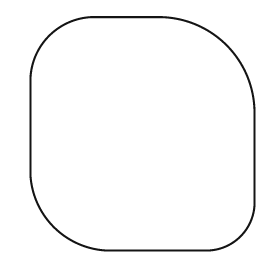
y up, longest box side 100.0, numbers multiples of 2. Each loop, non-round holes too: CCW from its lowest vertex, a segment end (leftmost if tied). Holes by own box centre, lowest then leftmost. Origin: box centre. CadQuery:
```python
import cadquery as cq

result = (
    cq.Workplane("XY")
    .moveTo(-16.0, -50.0)
    .lineTo(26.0, -50.0)
    .threePointArc((42.0, -44.0), (48.0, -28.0))
    .lineTo(48.0, 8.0)
    .threePointArc((36.0, 38.0), (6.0, 50.0))
    .lineTo(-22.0, 50.0)
    .threePointArc((-40.0, 42.0), (-48.0, 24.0))
    .lineTo(-48.0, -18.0)
    .threePointArc((-38.0, -40.0), (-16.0, -50.0))
    .close()
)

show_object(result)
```